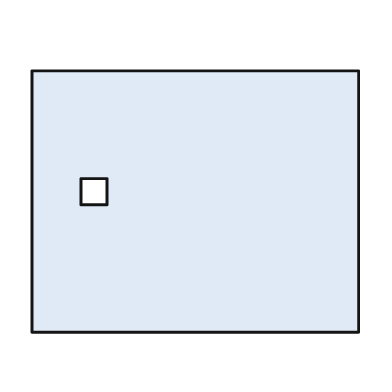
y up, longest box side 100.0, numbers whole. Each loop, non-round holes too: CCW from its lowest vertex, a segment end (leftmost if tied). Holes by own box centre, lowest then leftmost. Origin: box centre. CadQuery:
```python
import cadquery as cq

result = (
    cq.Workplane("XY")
    .moveTo(-50.0, -40.0)
    .lineTo(50.0, -40.0)
    .lineTo(50.0, 40.0)
    .lineTo(-50.0, 40.0)
    .close()
    .moveTo(-35.0, -1.0)
    .lineTo(-27.0, -1.0)
    .lineTo(-27.0, 7.0)
    .lineTo(-35.0, 7.0)
    .close()
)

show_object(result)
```